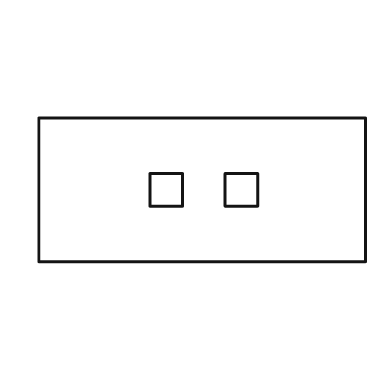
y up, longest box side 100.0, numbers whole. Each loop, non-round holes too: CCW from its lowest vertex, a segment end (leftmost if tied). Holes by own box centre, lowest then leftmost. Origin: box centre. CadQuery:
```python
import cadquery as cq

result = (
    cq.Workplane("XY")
    .moveTo(-50.0, -22.0)
    .lineTo(50.0, -22.0)
    .lineTo(50.0, 22.0)
    .lineTo(-50.0, 22.0)
    .close()
    .moveTo(-16.0, -5.0)
    .lineTo(-6.0, -5.0)
    .lineTo(-6.0, 5.0)
    .lineTo(-16.0, 5.0)
    .close()
    .moveTo(7.0, -5.0)
    .lineTo(17.0, -5.0)
    .lineTo(17.0, 5.0)
    .lineTo(7.0, 5.0)
    .close()
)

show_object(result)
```